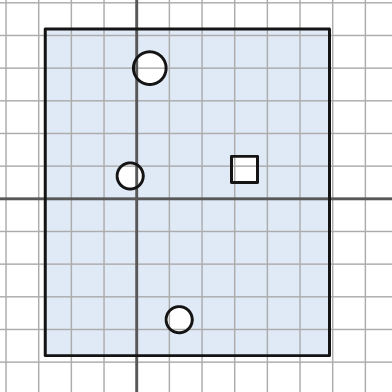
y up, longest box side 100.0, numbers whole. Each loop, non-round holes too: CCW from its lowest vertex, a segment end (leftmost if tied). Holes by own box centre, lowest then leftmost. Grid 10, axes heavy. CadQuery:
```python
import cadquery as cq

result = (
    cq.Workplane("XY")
    .moveTo(-28.0, -48.0)
    .lineTo(59.0, -48.0)
    .lineTo(59.0, 52.0)
    .lineTo(-28.0, 52.0)
    .close()
    .moveTo(13.0, -37.0)
    .circle(4.0)
    .moveTo(-2.0, 7.0)
    .circle(4.0)
    .moveTo(29.0, 5.0)
    .lineTo(37.0, 5.0)
    .lineTo(37.0, 13.0)
    .lineTo(29.0, 13.0)
    .close()
    .moveTo(4.0, 40.0)
    .circle(5.0)
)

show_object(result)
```